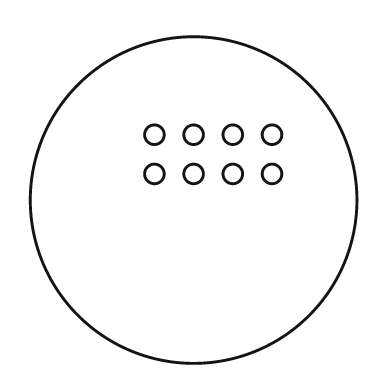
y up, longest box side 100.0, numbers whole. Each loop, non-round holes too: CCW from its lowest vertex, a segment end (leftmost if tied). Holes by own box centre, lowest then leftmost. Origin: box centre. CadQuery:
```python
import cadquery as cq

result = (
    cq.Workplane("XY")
    .moveTo(0.0, 0.0)
    .circle(50.0)
    .moveTo(-12.0, 8.0)
    .circle(3.0)
    .moveTo(0.0, 8.0)
    .circle(3.0)
    .moveTo(12.0, 8.0)
    .circle(3.0)
    .moveTo(24.0, 8.0)
    .circle(3.0)
    .moveTo(-12.0, 20.0)
    .circle(3.0)
    .moveTo(0.0, 20.0)
    .circle(3.0)
    .moveTo(12.0, 20.0)
    .circle(3.0)
    .moveTo(24.0, 20.0)
    .circle(3.0)
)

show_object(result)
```